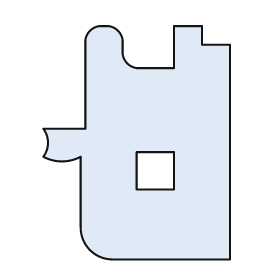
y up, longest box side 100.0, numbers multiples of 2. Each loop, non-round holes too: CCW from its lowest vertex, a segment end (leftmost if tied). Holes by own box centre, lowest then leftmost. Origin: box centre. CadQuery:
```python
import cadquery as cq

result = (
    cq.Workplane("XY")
    .moveTo(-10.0, -50.0)
    .lineTo(40.0, -50.0)
    .lineTo(40.0, 42.0)
    .lineTo(28.0, 42.0)
    .lineTo(28.0, 50.0)
    .lineTo(16.0, 50.0)
    .lineTo(16.0, 32.0)
    .lineTo(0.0, 32.0)
    .threePointArc((-4.0, 34.0), (-6.0, 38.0))
    .lineTo(-6.0, 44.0)
    .threePointArc((-8.0, 48.0), (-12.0, 50.0))
    .lineTo(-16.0, 50.0)
    .threePointArc((-20.0, 48.0), (-22.0, 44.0))
    .lineTo(-22.0, 6.0)
    .lineTo(-40.0, 6.0)
    .threePointArc((-38.0, 0.0), (-40.0, -6.0))
    .threePointArc((-32.0, -8.0), (-24.0, -6.0))
    .lineTo(-24.0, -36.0)
    .threePointArc((-20.0, -46.0), (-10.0, -50.0))
    .close()
    .moveTo(0.0, -20.0)
    .lineTo(16.0, -20.0)
    .lineTo(16.0, -4.0)
    .lineTo(0.0, -4.0)
    .close()
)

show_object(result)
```